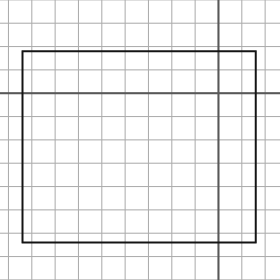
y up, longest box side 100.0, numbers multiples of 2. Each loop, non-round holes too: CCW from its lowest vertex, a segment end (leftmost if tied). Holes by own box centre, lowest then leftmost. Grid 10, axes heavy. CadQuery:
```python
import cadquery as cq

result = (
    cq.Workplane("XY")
    .moveTo(-84.0, -64.0)
    .lineTo(16.0, -64.0)
    .lineTo(16.0, 18.0)
    .lineTo(-84.0, 18.0)
    .close()
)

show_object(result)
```